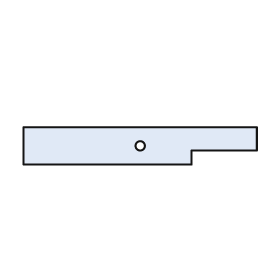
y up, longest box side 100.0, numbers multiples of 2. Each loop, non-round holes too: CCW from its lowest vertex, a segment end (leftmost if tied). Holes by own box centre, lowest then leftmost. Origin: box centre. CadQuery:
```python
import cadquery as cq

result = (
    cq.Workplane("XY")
    .moveTo(-50.0, -8.0)
    .lineTo(22.0, -8.0)
    .lineTo(22.0, -2.0)
    .lineTo(50.0, -2.0)
    .lineTo(50.0, 8.0)
    .lineTo(-50.0, 8.0)
    .close()
    .moveTo(0.0, 0.0)
    .circle(2.0)
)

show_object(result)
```